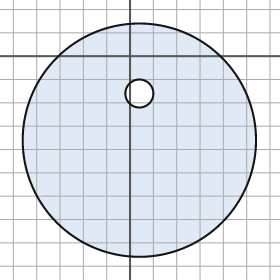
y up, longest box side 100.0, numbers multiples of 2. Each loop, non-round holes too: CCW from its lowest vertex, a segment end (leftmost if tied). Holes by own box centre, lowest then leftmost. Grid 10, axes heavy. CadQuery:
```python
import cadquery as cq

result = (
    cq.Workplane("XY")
    .moveTo(4.0, -36.0)
    .circle(50.0)
    .moveTo(4.0, -16.0)
    .circle(6.0)
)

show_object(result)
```